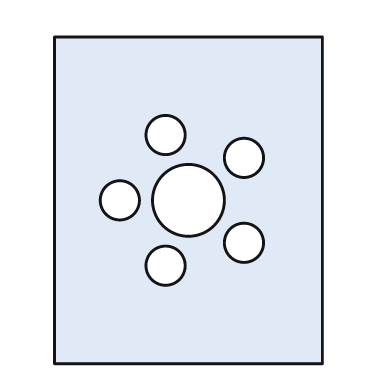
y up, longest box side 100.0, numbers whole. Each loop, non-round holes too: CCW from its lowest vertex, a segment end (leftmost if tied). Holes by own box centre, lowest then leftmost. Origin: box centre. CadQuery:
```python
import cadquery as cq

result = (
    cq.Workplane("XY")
    .moveTo(-41.0, -50.0)
    .lineTo(41.0, -50.0)
    .lineTo(41.0, 50.0)
    .lineTo(-41.0, 50.0)
    .close()
    .moveTo(-7.0, -20.0)
    .circle(6.0)
    .moveTo(17.0, -13.0)
    .circle(6.0)
    .moveTo(-21.0, 0.0)
    .circle(6.0)
    .moveTo(0.0, 0.0)
    .circle(11.0)
    .moveTo(17.0, 13.0)
    .circle(6.0)
    .moveTo(-7.0, 20.0)
    .circle(6.0)
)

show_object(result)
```